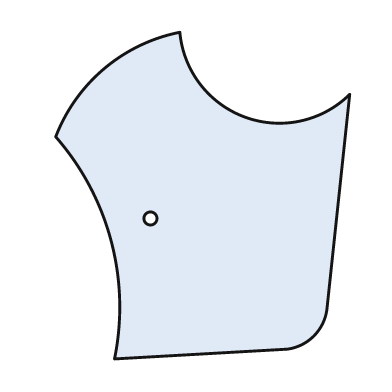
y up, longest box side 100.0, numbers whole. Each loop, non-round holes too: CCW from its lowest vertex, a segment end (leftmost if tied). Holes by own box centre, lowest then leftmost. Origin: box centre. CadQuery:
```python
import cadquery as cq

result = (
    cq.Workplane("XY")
    .moveTo(-27.0, -50.0)
    .lineTo(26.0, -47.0)
    .threePointArc((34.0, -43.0), (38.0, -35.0))
    .lineTo(45.0, 31.0)
    .threePointArc((13.0, 24.0), (-7.0, 50.0))
    .threePointArc((-30.0, 39.0), (-45.0, 18.0))
    .threePointArc((-28.0, -14.0), (-27.0, -50.0))
    .close()
    .moveTo(-16.0, -7.0)
    .circle(2.0)
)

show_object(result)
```